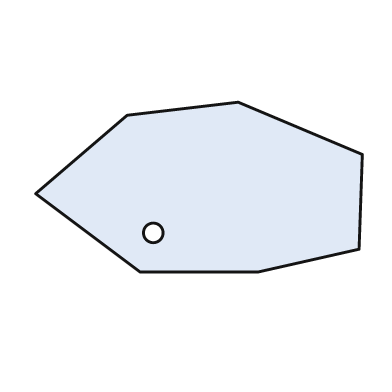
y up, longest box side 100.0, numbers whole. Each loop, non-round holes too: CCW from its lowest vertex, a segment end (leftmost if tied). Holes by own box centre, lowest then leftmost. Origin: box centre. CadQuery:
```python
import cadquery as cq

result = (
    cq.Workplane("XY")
    .moveTo(-18.0, -26.0)
    .lineTo(18.0, -26.0)
    .lineTo(49.0, -19.0)
    .lineTo(50.0, 10.0)
    .lineTo(12.0, 26.0)
    .lineTo(-22.0, 22.0)
    .lineTo(-50.0, -2.0)
    .close()
    .moveTo(-14.0, -14.0)
    .circle(3.0)
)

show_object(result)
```